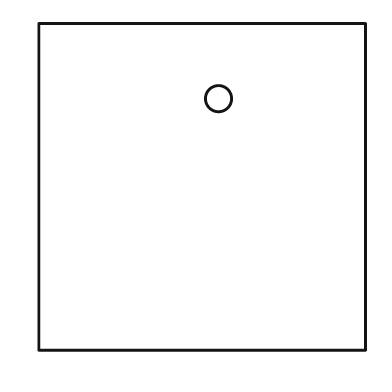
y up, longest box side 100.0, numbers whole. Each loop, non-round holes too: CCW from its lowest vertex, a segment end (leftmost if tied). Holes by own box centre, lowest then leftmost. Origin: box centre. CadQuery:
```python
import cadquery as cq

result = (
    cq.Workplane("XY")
    .moveTo(-50.0, -50.0)
    .lineTo(50.0, -50.0)
    .lineTo(50.0, 50.0)
    .lineTo(-50.0, 50.0)
    .close()
    .moveTo(5.0, 27.0)
    .circle(4.0)
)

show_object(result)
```